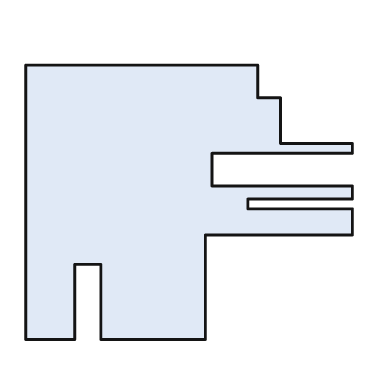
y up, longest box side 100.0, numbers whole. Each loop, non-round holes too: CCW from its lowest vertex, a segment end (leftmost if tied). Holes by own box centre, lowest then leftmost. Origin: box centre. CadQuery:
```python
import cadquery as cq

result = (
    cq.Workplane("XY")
    .moveTo(-50.0, -42.0)
    .lineTo(-35.0, -42.0)
    .lineTo(-35.0, -19.0)
    .lineTo(-27.0, -19.0)
    .lineTo(-27.0, -42.0)
    .lineTo(5.0, -42.0)
    .lineTo(5.0, -10.0)
    .lineTo(50.0, -10.0)
    .lineTo(50.0, -2.0)
    .lineTo(18.0, -2.0)
    .lineTo(18.0, 1.0)
    .lineTo(50.0, 1.0)
    .lineTo(50.0, 5.0)
    .lineTo(7.0, 5.0)
    .lineTo(7.0, 15.0)
    .lineTo(50.0, 15.0)
    .lineTo(50.0, 18.0)
    .lineTo(28.0, 18.0)
    .lineTo(28.0, 32.0)
    .lineTo(21.0, 32.0)
    .lineTo(21.0, 42.0)
    .lineTo(-50.0, 42.0)
    .close()
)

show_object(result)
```